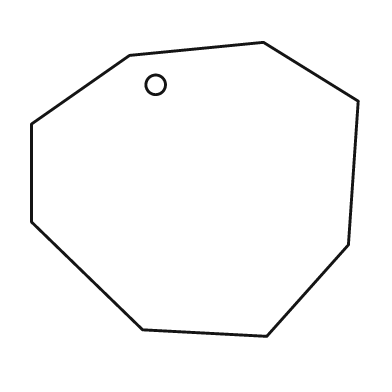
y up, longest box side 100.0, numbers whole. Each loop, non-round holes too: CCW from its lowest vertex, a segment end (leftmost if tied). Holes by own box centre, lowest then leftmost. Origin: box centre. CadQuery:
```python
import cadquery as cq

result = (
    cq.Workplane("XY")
    .moveTo(22.0, -45.0)
    .lineTo(47.0, -17.0)
    .lineTo(50.0, 27.0)
    .lineTo(21.0, 45.0)
    .lineTo(-20.0, 41.0)
    .lineTo(-50.0, 20.0)
    .lineTo(-50.0, -10.0)
    .lineTo(-16.0, -43.0)
    .close()
    .moveTo(-12.0, 32.0)
    .circle(3.0)
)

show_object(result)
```